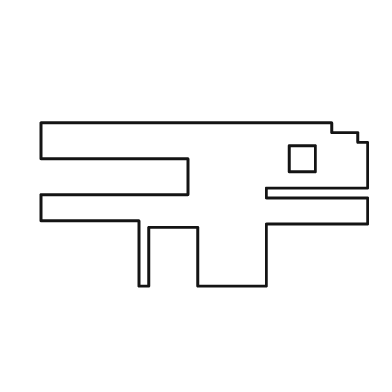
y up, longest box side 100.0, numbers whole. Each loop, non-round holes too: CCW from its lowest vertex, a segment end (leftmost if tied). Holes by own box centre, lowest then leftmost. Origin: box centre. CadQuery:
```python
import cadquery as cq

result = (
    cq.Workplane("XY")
    .moveTo(-20.0, -25.0)
    .lineTo(-17.0, -25.0)
    .lineTo(-17.0, -7.0)
    .lineTo(-2.0, -7.0)
    .lineTo(-2.0, -25.0)
    .lineTo(19.0, -25.0)
    .lineTo(19.0, -6.0)
    .lineTo(50.0, -6.0)
    .lineTo(50.0, 2.0)
    .lineTo(19.0, 2.0)
    .lineTo(19.0, 5.0)
    .lineTo(50.0, 5.0)
    .lineTo(50.0, 19.0)
    .lineTo(47.0, 19.0)
    .lineTo(47.0, 22.0)
    .lineTo(39.0, 22.0)
    .lineTo(39.0, 25.0)
    .lineTo(-50.0, 25.0)
    .lineTo(-50.0, 14.0)
    .lineTo(-5.0, 14.0)
    .lineTo(-5.0, 3.0)
    .lineTo(-50.0, 3.0)
    .lineTo(-50.0, -5.0)
    .lineTo(-20.0, -5.0)
    .close()
    .moveTo(26.0, 10.0)
    .lineTo(34.0, 10.0)
    .lineTo(34.0, 18.0)
    .lineTo(26.0, 18.0)
    .close()
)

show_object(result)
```